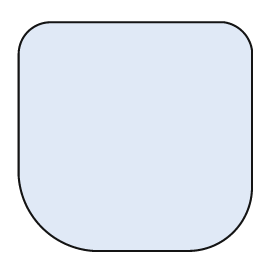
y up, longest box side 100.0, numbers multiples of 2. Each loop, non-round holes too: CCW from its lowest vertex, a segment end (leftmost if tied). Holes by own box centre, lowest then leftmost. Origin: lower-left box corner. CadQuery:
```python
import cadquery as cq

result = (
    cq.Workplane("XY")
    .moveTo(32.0, 0.0)
    .lineTo(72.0, 0.0)
    .threePointArc((92.0, 8.0), (100.0, 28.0))
    .lineTo(100.0, 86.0)
    .threePointArc((96.0, 94.0), (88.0, 98.0))
    .lineTo(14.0, 98.0)
    .threePointArc((4.0, 94.0), (0.0, 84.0))
    .lineTo(0.0, 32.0)
    .threePointArc((10.0, 10.0), (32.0, 0.0))
    .close()
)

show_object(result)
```